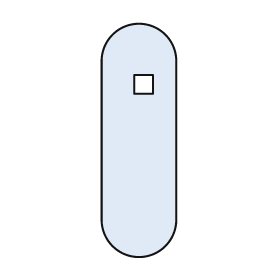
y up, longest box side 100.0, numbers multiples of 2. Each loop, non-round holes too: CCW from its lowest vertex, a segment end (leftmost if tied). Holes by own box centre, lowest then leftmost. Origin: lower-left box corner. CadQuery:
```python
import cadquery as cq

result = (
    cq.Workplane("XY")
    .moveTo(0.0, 16.0)
    .threePointArc((16.0, 0.0), (32.0, 16.0))
    .lineTo(32.0, 84.0)
    .threePointArc((16.0, 100.0), (0.0, 84.0))
    .close()
    .moveTo(14.0, 70.0)
    .lineTo(22.0, 70.0)
    .lineTo(22.0, 78.0)
    .lineTo(14.0, 78.0)
    .close()
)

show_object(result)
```